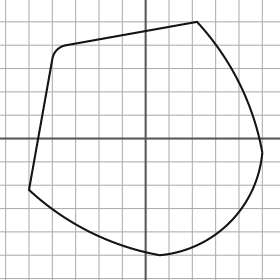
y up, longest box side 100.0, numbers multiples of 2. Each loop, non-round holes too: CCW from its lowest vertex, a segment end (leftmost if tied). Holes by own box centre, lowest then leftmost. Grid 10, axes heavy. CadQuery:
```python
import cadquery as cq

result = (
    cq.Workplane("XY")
    .moveTo(6.0, -50.0)
    .threePointArc((36.0, -36.0), (50.0, -6.0))
    .threePointArc((40.0, 24.0), (22.0, 50.0))
    .lineTo(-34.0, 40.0)
    .threePointArc((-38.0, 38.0), (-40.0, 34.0))
    .lineTo(-50.0, -22.0)
    .threePointArc((-24.0, -40.0), (6.0, -50.0))
    .close()
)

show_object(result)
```